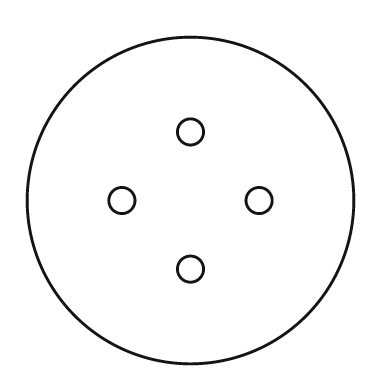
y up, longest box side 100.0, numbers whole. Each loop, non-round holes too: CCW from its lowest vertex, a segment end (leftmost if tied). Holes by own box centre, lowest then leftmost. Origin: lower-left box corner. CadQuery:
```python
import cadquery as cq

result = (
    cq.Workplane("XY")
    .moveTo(50.0, 50.0)
    .circle(50.0)
    .moveTo(50.0, 29.0)
    .circle(4.0)
    .moveTo(29.0, 50.0)
    .circle(4.0)
    .moveTo(71.0, 50.0)
    .circle(4.0)
    .moveTo(50.0, 71.0)
    .circle(4.0)
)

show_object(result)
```